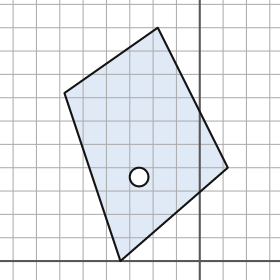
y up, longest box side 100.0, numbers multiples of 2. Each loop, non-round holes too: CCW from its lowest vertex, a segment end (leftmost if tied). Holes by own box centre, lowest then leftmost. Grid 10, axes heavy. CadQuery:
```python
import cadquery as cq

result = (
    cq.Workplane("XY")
    .moveTo(-34.0, 0.0)
    .lineTo(12.0, 40.0)
    .lineTo(-18.0, 100.0)
    .lineTo(-58.0, 72.0)
    .close()
    .moveTo(-26.0, 36.0)
    .circle(4.0)
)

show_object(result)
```